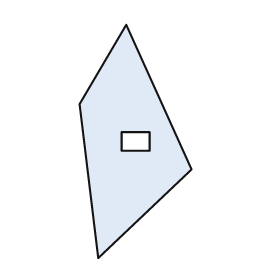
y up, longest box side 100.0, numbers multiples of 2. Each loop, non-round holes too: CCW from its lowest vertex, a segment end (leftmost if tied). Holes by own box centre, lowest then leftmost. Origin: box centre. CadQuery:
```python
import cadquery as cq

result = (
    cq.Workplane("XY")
    .moveTo(-16.0, -50.0)
    .lineTo(24.0, -12.0)
    .lineTo(-4.0, 50.0)
    .lineTo(-24.0, 16.0)
    .close()
    .moveTo(-6.0, -4.0)
    .lineTo(6.0, -4.0)
    .lineTo(6.0, 4.0)
    .lineTo(-6.0, 4.0)
    .close()
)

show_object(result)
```